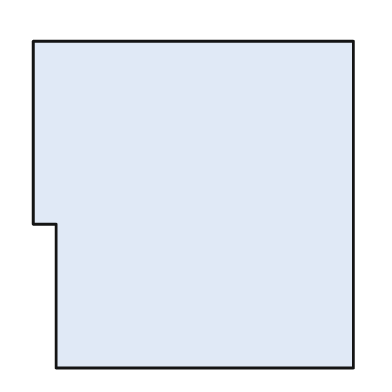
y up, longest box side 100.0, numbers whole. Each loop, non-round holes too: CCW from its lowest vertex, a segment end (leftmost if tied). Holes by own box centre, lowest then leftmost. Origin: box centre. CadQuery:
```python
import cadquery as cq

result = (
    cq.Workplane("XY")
    .moveTo(-42.0, -50.0)
    .lineTo(49.0, -50.0)
    .lineTo(49.0, 50.0)
    .lineTo(-49.0, 50.0)
    .lineTo(-49.0, -6.0)
    .lineTo(-42.0, -6.0)
    .close()
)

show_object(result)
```